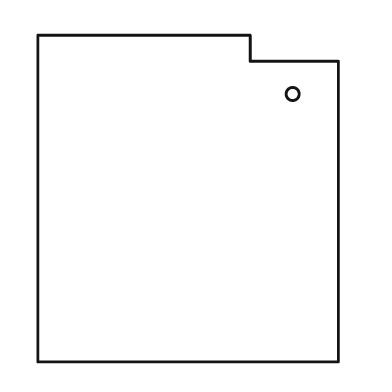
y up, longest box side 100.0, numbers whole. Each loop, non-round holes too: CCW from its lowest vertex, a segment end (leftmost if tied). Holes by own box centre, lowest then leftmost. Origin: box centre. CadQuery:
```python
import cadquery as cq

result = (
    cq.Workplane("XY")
    .moveTo(-46.0, -50.0)
    .lineTo(46.0, -50.0)
    .lineTo(46.0, 42.0)
    .lineTo(19.0, 42.0)
    .lineTo(19.0, 50.0)
    .lineTo(-46.0, 50.0)
    .close()
    .moveTo(32.0, 32.0)
    .circle(2.0)
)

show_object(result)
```